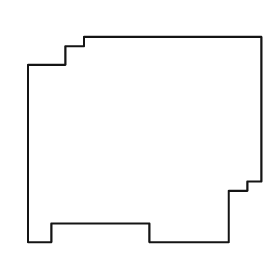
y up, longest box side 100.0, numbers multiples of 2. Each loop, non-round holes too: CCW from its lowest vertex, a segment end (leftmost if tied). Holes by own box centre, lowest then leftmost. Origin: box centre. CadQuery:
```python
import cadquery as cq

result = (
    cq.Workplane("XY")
    .moveTo(-50.0, -44.0)
    .lineTo(-40.0, -44.0)
    .lineTo(-40.0, -36.0)
    .lineTo(2.0, -36.0)
    .lineTo(2.0, -44.0)
    .lineTo(36.0, -44.0)
    .lineTo(36.0, -22.0)
    .lineTo(44.0, -22.0)
    .lineTo(44.0, -18.0)
    .lineTo(50.0, -18.0)
    .lineTo(50.0, 44.0)
    .lineTo(-26.0, 44.0)
    .lineTo(-26.0, 40.0)
    .lineTo(-34.0, 40.0)
    .lineTo(-34.0, 32.0)
    .lineTo(-50.0, 32.0)
    .close()
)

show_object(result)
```